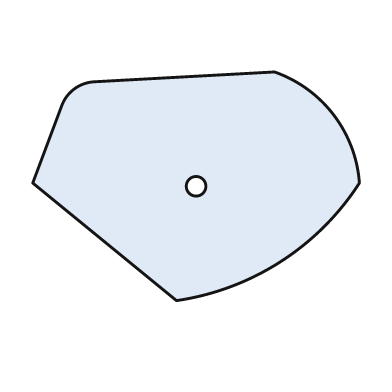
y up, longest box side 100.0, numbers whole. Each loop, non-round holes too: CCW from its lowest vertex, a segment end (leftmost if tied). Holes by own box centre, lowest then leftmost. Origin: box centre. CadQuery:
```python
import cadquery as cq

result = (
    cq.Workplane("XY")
    .moveTo(-6.0, -35.0)
    .threePointArc((26.0, -23.0), (50.0, 1.0))
    .threePointArc((42.0, 22.0), (24.0, 35.0))
    .lineTo(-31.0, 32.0)
    .threePointArc((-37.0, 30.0), (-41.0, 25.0))
    .lineTo(-50.0, 1.0)
    .close()
    .moveTo(0.0, 0.0)
    .circle(3.0)
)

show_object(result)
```